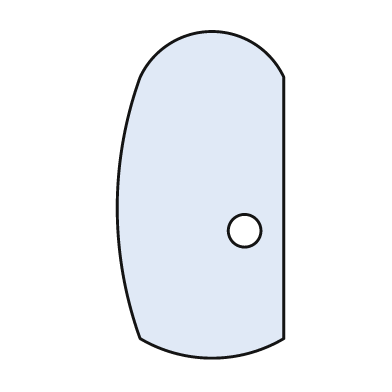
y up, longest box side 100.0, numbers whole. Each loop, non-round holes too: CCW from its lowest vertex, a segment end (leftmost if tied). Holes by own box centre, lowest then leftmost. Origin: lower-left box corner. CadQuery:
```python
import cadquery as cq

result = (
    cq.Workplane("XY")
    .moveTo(7.0, 6.0)
    .threePointArc((29.0, 0.0), (51.0, 6.0))
    .lineTo(51.0, 86.0)
    .threePointArc((29.0, 100.0), (7.0, 86.0))
    .threePointArc((0.0, 46.0), (7.0, 6.0))
    .close()
    .moveTo(39.0, 39.0)
    .circle(5.0)
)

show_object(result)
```